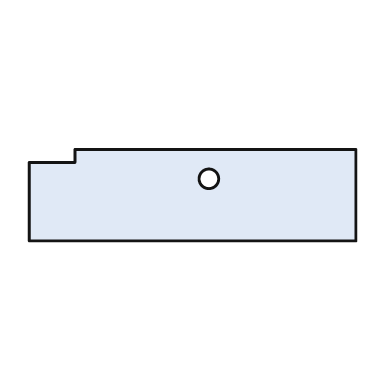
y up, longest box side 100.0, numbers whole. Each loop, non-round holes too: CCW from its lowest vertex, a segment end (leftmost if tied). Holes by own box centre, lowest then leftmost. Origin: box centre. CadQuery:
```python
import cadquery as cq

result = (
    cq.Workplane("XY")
    .moveTo(-50.0, -14.0)
    .lineTo(50.0, -14.0)
    .lineTo(50.0, 14.0)
    .lineTo(-36.0, 14.0)
    .lineTo(-36.0, 10.0)
    .lineTo(-50.0, 10.0)
    .close()
    .moveTo(5.0, 5.0)
    .circle(3.0)
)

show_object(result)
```